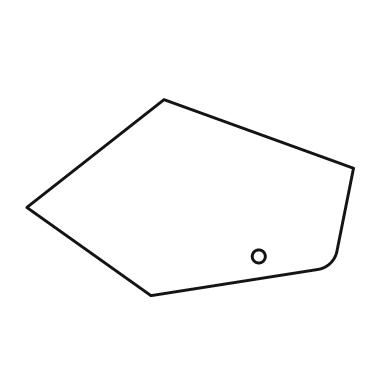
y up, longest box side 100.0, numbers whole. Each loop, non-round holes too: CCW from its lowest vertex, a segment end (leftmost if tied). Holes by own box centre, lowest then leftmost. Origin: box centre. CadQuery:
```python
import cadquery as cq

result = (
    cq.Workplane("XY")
    .moveTo(-12.0, -30.0)
    .lineTo(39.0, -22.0)
    .threePointArc((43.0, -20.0), (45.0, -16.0))
    .lineTo(50.0, 9.0)
    .lineTo(-8.0, 30.0)
    .lineTo(-50.0, -3.0)
    .close()
    .moveTo(21.0, -18.0)
    .circle(2.0)
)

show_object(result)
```